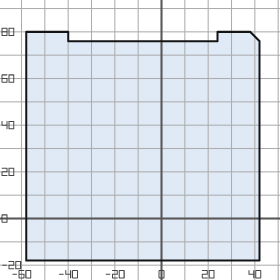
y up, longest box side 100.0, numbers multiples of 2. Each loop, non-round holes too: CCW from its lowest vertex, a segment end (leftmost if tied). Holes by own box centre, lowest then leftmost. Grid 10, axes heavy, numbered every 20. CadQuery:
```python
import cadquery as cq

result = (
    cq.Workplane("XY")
    .moveTo(-58.0, -18.0)
    .lineTo(42.0, -18.0)
    .lineTo(42.0, 76.0)
    .lineTo(38.0, 80.0)
    .lineTo(24.0, 80.0)
    .lineTo(24.0, 76.0)
    .lineTo(-40.0, 76.0)
    .lineTo(-40.0, 80.0)
    .lineTo(-58.0, 80.0)
    .close()
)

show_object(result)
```